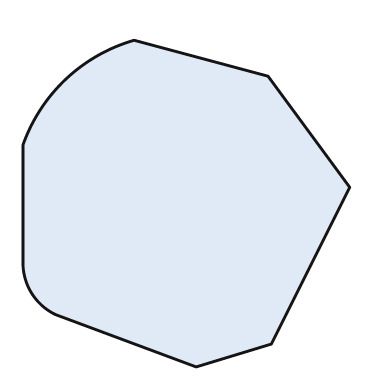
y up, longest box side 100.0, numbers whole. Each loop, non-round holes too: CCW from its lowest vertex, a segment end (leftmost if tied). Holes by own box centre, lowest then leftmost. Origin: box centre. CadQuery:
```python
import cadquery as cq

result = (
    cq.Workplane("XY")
    .moveTo(3.0, -50.0)
    .lineTo(26.0, -43.0)
    .lineTo(50.0, 5.0)
    .lineTo(25.0, 39.0)
    .lineTo(-16.0, 50.0)
    .threePointArc((-37.0, 38.0), (-50.0, 18.0))
    .lineTo(-50.0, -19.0)
    .threePointArc((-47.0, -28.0), (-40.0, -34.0))
    .close()
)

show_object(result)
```